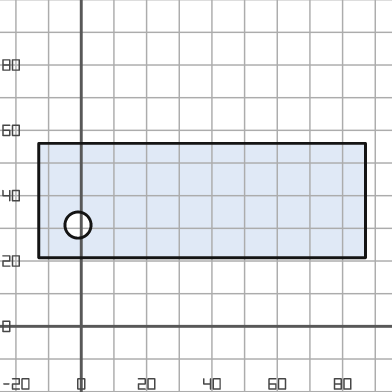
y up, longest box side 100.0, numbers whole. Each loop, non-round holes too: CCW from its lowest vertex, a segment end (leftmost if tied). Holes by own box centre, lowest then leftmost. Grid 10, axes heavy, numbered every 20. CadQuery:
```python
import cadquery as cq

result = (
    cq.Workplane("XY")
    .moveTo(-13.0, 21.0)
    .lineTo(87.0, 21.0)
    .lineTo(87.0, 56.0)
    .lineTo(-13.0, 56.0)
    .close()
    .moveTo(-1.0, 31.0)
    .circle(4.0)
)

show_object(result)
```